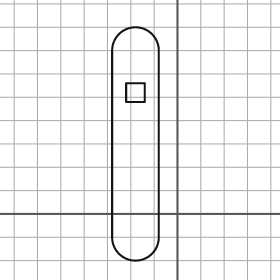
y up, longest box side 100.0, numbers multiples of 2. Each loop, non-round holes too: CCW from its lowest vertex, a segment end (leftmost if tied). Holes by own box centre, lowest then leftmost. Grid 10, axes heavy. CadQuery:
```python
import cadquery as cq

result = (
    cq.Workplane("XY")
    .moveTo(-28.0, -10.0)
    .threePointArc((-18.0, -20.0), (-8.0, -10.0))
    .lineTo(-8.0, 70.0)
    .threePointArc((-18.0, 80.0), (-28.0, 70.0))
    .close()
    .moveTo(-22.0, 48.0)
    .lineTo(-14.0, 48.0)
    .lineTo(-14.0, 56.0)
    .lineTo(-22.0, 56.0)
    .close()
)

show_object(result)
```